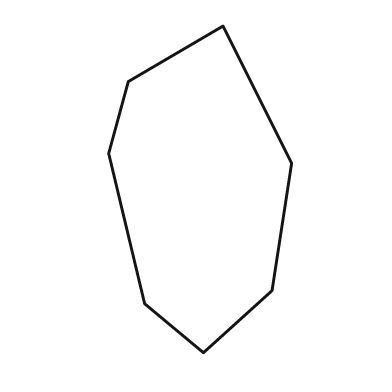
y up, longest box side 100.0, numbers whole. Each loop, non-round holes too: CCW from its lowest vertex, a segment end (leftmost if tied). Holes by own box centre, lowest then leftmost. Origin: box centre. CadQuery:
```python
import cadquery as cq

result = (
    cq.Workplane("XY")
    .moveTo(1.0, -50.0)
    .lineTo(22.0, -31.0)
    .lineTo(28.0, 8.0)
    .lineTo(7.0, 50.0)
    .lineTo(-22.0, 33.0)
    .lineTo(-28.0, 11.0)
    .lineTo(-17.0, -35.0)
    .close()
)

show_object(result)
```